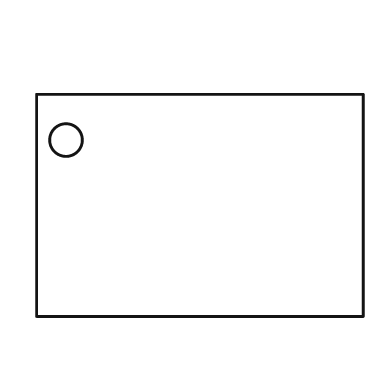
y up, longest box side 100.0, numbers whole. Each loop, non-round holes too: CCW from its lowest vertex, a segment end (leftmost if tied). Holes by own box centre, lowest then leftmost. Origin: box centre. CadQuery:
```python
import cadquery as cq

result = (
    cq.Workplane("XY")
    .moveTo(-50.0, -34.0)
    .lineTo(50.0, -34.0)
    .lineTo(50.0, 34.0)
    .lineTo(-50.0, 34.0)
    .close()
    .moveTo(-41.0, 20.0)
    .circle(5.0)
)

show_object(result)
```